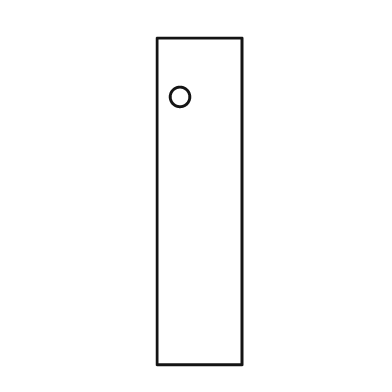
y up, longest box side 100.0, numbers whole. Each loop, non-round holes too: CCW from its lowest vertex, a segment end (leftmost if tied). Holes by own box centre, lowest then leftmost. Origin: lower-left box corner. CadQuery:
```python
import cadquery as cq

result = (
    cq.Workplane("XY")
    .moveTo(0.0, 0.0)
    .lineTo(26.0, 0.0)
    .lineTo(26.0, 100.0)
    .lineTo(0.0, 100.0)
    .close()
    .moveTo(7.0, 82.0)
    .circle(3.0)
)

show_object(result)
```